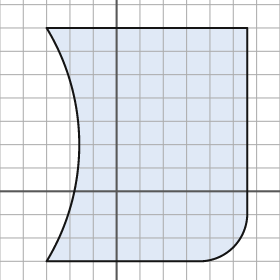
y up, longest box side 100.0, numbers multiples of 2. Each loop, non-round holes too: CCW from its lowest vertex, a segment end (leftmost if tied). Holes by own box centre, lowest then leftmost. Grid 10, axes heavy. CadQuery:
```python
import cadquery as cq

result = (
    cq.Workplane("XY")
    .moveTo(-30.0, -30.0)
    .lineTo(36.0, -30.0)
    .threePointArc((50.0, -24.0), (56.0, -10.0))
    .lineTo(56.0, 70.0)
    .lineTo(-30.0, 70.0)
    .threePointArc((-16.0, 20.0), (-30.0, -30.0))
    .close()
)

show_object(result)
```